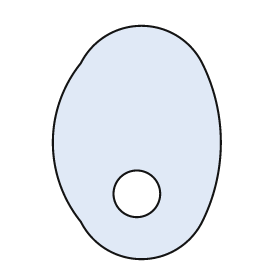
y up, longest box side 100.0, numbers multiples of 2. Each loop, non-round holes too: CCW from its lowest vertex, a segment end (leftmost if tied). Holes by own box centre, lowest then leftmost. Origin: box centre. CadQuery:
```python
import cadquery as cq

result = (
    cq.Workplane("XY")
    .moveTo(-24.0, -34.0)
    .threePointArc((2.0, -50.0), (28.0, -34.0))
    .threePointArc((36.0, 0.0), (28.0, 34.0))
    .threePointArc((2.0, 50.0), (-24.0, 34.0))
    .threePointArc((-36.0, 0.0), (-24.0, -34.0))
    .close()
    .moveTo(0.0, -22.0)
    .circle(10.0)
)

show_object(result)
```